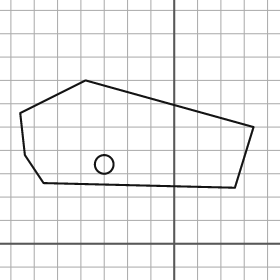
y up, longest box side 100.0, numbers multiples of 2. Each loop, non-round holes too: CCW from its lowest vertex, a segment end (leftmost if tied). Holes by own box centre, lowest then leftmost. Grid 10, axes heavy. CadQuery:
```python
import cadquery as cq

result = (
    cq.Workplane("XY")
    .moveTo(26.0, 24.0)
    .lineTo(34.0, 50.0)
    .lineTo(-38.0, 70.0)
    .lineTo(-66.0, 56.0)
    .lineTo(-64.0, 38.0)
    .lineTo(-56.0, 26.0)
    .close()
    .moveTo(-30.0, 34.0)
    .circle(4.0)
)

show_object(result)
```